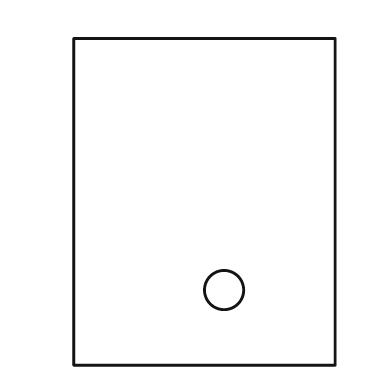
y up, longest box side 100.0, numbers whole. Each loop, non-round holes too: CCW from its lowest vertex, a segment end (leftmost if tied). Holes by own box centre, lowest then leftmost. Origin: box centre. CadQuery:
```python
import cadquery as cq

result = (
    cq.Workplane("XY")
    .moveTo(-40.0, -50.0)
    .lineTo(40.0, -50.0)
    .lineTo(40.0, 50.0)
    .lineTo(-40.0, 50.0)
    .close()
    .moveTo(6.0, -27.0)
    .circle(6.0)
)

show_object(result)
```